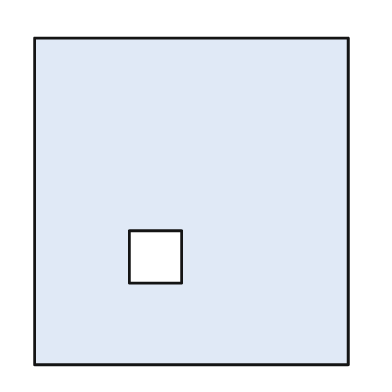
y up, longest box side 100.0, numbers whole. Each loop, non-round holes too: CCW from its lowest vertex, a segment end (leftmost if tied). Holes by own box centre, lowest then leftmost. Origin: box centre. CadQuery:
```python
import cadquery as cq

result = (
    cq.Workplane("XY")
    .moveTo(-48.0, -50.0)
    .lineTo(48.0, -50.0)
    .lineTo(48.0, 50.0)
    .lineTo(-48.0, 50.0)
    .close()
    .moveTo(-19.0, -25.0)
    .lineTo(-3.0, -25.0)
    .lineTo(-3.0, -9.0)
    .lineTo(-19.0, -9.0)
    .close()
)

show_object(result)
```